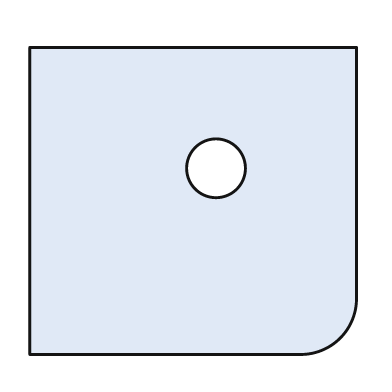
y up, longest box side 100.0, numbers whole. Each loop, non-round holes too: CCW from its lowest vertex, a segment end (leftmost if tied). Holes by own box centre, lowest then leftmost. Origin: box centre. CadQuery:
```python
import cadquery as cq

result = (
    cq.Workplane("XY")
    .moveTo(-50.0, -47.0)
    .lineTo(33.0, -47.0)
    .threePointArc((45.0, -42.0), (50.0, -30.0))
    .lineTo(50.0, 47.0)
    .lineTo(-50.0, 47.0)
    .close()
    .moveTo(7.0, 10.0)
    .circle(9.0)
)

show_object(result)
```